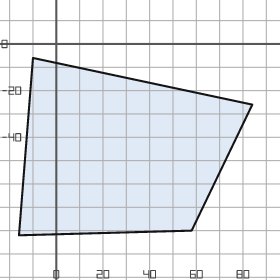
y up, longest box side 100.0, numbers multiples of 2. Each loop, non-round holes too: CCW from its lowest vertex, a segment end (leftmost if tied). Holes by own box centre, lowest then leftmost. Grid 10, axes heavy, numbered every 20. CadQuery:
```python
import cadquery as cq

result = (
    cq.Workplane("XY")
    .moveTo(-16.0, -82.0)
    .lineTo(58.0, -80.0)
    .lineTo(84.0, -26.0)
    .lineTo(-10.0, -6.0)
    .close()
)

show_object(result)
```